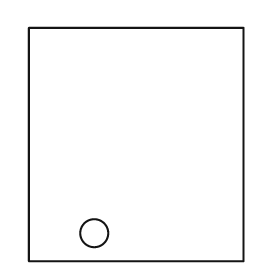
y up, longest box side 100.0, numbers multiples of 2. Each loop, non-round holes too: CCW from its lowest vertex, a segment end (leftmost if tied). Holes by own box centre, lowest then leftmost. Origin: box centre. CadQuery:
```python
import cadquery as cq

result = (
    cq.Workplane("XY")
    .moveTo(-46.0, -50.0)
    .lineTo(46.0, -50.0)
    .lineTo(46.0, 50.0)
    .lineTo(-46.0, 50.0)
    .close()
    .moveTo(-18.0, -38.0)
    .circle(6.0)
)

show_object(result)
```